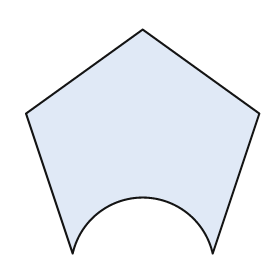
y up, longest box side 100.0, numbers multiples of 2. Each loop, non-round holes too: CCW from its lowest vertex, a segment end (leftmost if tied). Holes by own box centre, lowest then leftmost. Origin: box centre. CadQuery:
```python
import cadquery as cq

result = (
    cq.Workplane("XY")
    .moveTo(-30.0, -48.0)
    .threePointArc((0.0, -24.0), (30.0, -48.0))
    .lineTo(50.0, 12.0)
    .lineTo(0.0, 48.0)
    .lineTo(-50.0, 12.0)
    .close()
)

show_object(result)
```